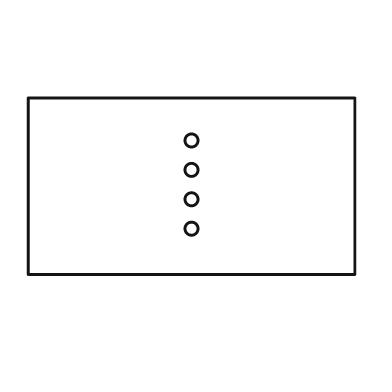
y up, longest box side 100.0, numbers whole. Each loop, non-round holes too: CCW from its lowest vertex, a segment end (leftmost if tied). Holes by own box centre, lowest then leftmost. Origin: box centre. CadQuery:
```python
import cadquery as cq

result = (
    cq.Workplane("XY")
    .moveTo(-50.0, -27.0)
    .lineTo(50.0, -27.0)
    .lineTo(50.0, 27.0)
    .lineTo(-50.0, 27.0)
    .close()
    .moveTo(0.0, -13.0)
    .circle(2.0)
    .moveTo(0.0, -4.0)
    .circle(2.0)
    .moveTo(0.0, 5.0)
    .circle(2.0)
    .moveTo(0.0, 14.0)
    .circle(2.0)
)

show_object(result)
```